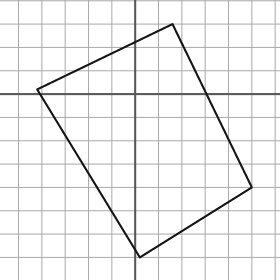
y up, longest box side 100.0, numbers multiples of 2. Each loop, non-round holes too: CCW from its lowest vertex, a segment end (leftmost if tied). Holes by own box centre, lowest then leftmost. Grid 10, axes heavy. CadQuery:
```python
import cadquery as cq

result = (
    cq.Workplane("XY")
    .moveTo(2.0, -70.0)
    .lineTo(50.0, -40.0)
    .lineTo(16.0, 30.0)
    .lineTo(-42.0, 2.0)
    .close()
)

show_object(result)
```